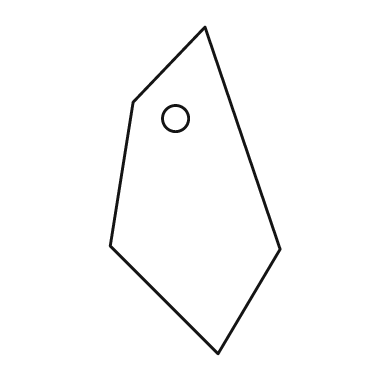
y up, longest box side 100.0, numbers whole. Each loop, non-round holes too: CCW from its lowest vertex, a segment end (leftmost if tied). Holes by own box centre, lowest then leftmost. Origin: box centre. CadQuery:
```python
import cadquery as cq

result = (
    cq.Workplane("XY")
    .moveTo(7.0, -50.0)
    .lineTo(26.0, -18.0)
    .lineTo(3.0, 50.0)
    .lineTo(-19.0, 27.0)
    .lineTo(-26.0, -17.0)
    .close()
    .moveTo(-6.0, 22.0)
    .circle(4.0)
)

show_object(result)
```